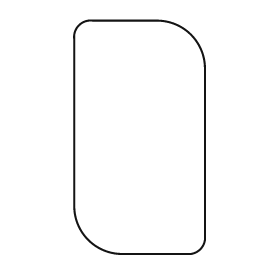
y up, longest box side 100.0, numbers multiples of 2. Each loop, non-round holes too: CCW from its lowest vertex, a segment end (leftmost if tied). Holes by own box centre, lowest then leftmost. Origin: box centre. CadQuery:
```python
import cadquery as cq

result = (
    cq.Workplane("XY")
    .moveTo(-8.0, -50.0)
    .lineTo(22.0, -50.0)
    .threePointArc((26.0, -48.0), (28.0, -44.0))
    .lineTo(28.0, 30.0)
    .threePointArc((22.0, 44.0), (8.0, 50.0))
    .lineTo(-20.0, 50.0)
    .threePointArc((-26.0, 48.0), (-28.0, 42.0))
    .lineTo(-28.0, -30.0)
    .threePointArc((-22.0, -44.0), (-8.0, -50.0))
    .close()
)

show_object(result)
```